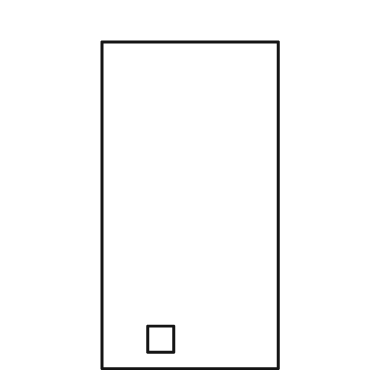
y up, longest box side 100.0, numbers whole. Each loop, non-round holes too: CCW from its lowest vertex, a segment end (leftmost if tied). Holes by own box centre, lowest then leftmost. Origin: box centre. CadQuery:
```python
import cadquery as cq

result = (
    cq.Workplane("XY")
    .moveTo(-27.0, -50.0)
    .lineTo(27.0, -50.0)
    .lineTo(27.0, 50.0)
    .lineTo(-27.0, 50.0)
    .close()
    .moveTo(-13.0, -45.0)
    .lineTo(-5.0, -45.0)
    .lineTo(-5.0, -37.0)
    .lineTo(-13.0, -37.0)
    .close()
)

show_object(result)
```